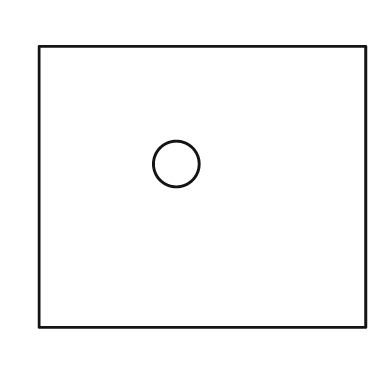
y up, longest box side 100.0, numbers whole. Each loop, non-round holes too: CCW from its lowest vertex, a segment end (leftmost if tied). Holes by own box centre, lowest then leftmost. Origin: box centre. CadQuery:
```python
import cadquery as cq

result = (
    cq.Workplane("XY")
    .moveTo(-50.0, -43.0)
    .lineTo(50.0, -43.0)
    .lineTo(50.0, 43.0)
    .lineTo(-50.0, 43.0)
    .close()
    .moveTo(-8.0, 7.0)
    .circle(7.0)
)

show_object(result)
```